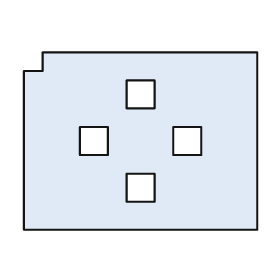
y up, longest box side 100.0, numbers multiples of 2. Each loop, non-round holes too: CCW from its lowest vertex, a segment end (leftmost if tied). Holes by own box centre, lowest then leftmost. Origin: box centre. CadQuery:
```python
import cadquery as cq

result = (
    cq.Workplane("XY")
    .moveTo(-50.0, -38.0)
    .lineTo(50.0, -38.0)
    .lineTo(50.0, 38.0)
    .lineTo(-42.0, 38.0)
    .lineTo(-42.0, 30.0)
    .lineTo(-50.0, 30.0)
    .close()
    .moveTo(-6.0, -26.0)
    .lineTo(6.0, -26.0)
    .lineTo(6.0, -14.0)
    .lineTo(-6.0, -14.0)
    .close()
    .moveTo(-26.0, -6.0)
    .lineTo(-14.0, -6.0)
    .lineTo(-14.0, 6.0)
    .lineTo(-26.0, 6.0)
    .close()
    .moveTo(14.0, -6.0)
    .lineTo(26.0, -6.0)
    .lineTo(26.0, 6.0)
    .lineTo(14.0, 6.0)
    .close()
    .moveTo(-6.0, 14.0)
    .lineTo(6.0, 14.0)
    .lineTo(6.0, 26.0)
    .lineTo(-6.0, 26.0)
    .close()
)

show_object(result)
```